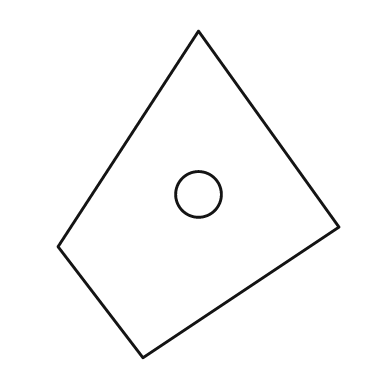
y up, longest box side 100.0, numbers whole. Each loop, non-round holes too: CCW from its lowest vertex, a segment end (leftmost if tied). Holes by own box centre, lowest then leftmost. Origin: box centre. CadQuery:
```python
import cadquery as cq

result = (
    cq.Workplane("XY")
    .moveTo(-17.0, -50.0)
    .lineTo(43.0, -10.0)
    .lineTo(0.0, 50.0)
    .lineTo(-43.0, -16.0)
    .close()
    .moveTo(0.0, 0.0)
    .circle(7.0)
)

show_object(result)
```